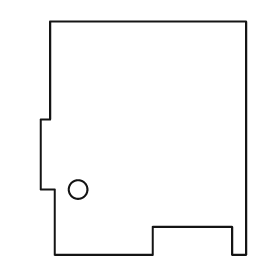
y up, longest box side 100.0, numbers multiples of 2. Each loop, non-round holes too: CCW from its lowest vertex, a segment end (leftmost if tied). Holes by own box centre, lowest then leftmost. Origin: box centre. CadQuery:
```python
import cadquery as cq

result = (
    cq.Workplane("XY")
    .moveTo(-38.0, -50.0)
    .lineTo(4.0, -50.0)
    .lineTo(4.0, -38.0)
    .lineTo(38.0, -38.0)
    .lineTo(38.0, -50.0)
    .lineTo(44.0, -50.0)
    .lineTo(44.0, 50.0)
    .lineTo(-40.0, 50.0)
    .lineTo(-40.0, 8.0)
    .lineTo(-44.0, 8.0)
    .lineTo(-44.0, -22.0)
    .lineTo(-38.0, -22.0)
    .close()
    .moveTo(-28.0, -22.0)
    .circle(4.0)
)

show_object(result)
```